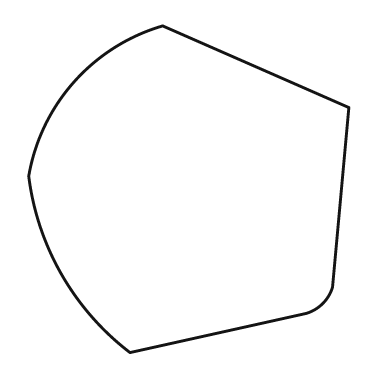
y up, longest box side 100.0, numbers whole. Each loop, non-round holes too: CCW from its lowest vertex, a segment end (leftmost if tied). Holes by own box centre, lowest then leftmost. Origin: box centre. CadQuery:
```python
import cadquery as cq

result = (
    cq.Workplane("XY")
    .moveTo(-18.0, -50.0)
    .lineTo(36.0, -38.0)
    .threePointArc((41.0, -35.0), (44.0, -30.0))
    .lineTo(49.0, 25.0)
    .lineTo(-8.0, 50.0)
    .threePointArc((-35.0, 33.0), (-49.0, 4.0))
    .threePointArc((-39.0, -26.0), (-18.0, -50.0))
    .close()
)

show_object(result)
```